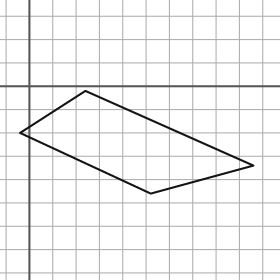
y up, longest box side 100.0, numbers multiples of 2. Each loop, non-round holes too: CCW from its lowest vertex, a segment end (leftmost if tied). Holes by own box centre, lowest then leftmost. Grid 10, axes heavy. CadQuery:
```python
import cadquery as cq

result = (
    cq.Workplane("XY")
    .moveTo(52.0, -46.0)
    .lineTo(96.0, -34.0)
    .lineTo(24.0, -2.0)
    .lineTo(-4.0, -20.0)
    .close()
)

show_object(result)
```